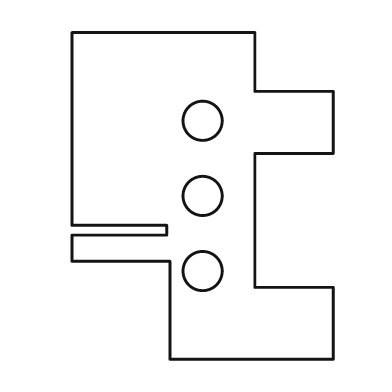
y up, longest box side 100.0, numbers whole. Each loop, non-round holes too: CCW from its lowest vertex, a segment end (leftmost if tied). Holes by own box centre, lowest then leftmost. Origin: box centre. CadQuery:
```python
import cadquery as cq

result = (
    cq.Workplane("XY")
    .moveTo(-10.0, -50.0)
    .lineTo(40.0, -50.0)
    .lineTo(40.0, -28.0)
    .lineTo(16.0, -28.0)
    .lineTo(16.0, 13.0)
    .lineTo(40.0, 13.0)
    .lineTo(40.0, 32.0)
    .lineTo(16.0, 32.0)
    .lineTo(16.0, 50.0)
    .lineTo(-40.0, 50.0)
    .lineTo(-40.0, -9.0)
    .lineTo(-11.0, -9.0)
    .lineTo(-11.0, -12.0)
    .lineTo(-40.0, -12.0)
    .lineTo(-40.0, -20.0)
    .lineTo(-10.0, -20.0)
    .close()
    .moveTo(0.0, -23.0)
    .circle(6.0)
    .moveTo(0.0, 0.0)
    .circle(6.0)
    .moveTo(0.0, 23.0)
    .circle(6.0)
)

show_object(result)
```